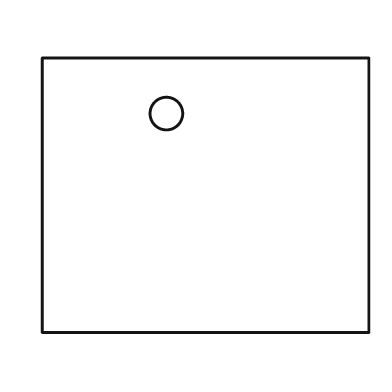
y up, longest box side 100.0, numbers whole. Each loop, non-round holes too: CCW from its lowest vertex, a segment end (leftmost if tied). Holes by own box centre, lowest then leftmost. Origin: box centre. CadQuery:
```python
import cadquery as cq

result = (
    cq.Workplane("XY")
    .moveTo(-50.0, -42.0)
    .lineTo(50.0, -42.0)
    .lineTo(50.0, 42.0)
    .lineTo(-50.0, 42.0)
    .close()
    .moveTo(-12.0, 25.0)
    .circle(5.0)
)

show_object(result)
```